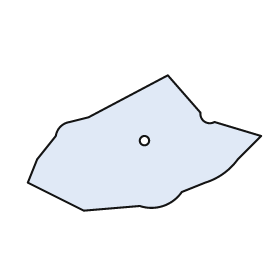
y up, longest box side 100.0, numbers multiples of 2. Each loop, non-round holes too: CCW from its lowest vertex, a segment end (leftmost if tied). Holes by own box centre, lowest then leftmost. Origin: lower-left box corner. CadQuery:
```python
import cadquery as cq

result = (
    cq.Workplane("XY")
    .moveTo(24.0, 0.0)
    .lineTo(48.0, 2.0)
    .threePointArc((58.0, 2.0), (66.0, 8.0))
    .lineTo(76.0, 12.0)
    .threePointArc((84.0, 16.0), (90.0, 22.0))
    .lineTo(100.0, 32.0)
    .lineTo(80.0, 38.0)
    .threePointArc((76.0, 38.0), (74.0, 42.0))
    .lineTo(60.0, 58.0)
    .lineTo(26.0, 40.0)
    .lineTo(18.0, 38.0)
    .threePointArc((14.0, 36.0), (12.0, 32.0))
    .lineTo(4.0, 22.0)
    .lineTo(0.0, 12.0)
    .close()
    .moveTo(50.0, 30.0)
    .circle(2.0)
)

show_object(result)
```